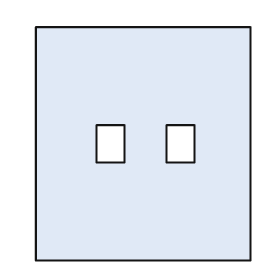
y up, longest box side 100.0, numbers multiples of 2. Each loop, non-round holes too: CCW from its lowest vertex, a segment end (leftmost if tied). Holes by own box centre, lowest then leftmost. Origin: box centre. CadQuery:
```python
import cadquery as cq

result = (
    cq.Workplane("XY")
    .moveTo(-46.0, -50.0)
    .lineTo(46.0, -50.0)
    .lineTo(46.0, 50.0)
    .lineTo(-46.0, 50.0)
    .close()
    .moveTo(-20.0, -8.0)
    .lineTo(-8.0, -8.0)
    .lineTo(-8.0, 8.0)
    .lineTo(-20.0, 8.0)
    .close()
    .moveTo(10.0, -8.0)
    .lineTo(22.0, -8.0)
    .lineTo(22.0, 8.0)
    .lineTo(10.0, 8.0)
    .close()
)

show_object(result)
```